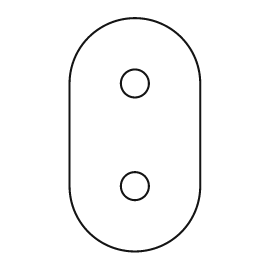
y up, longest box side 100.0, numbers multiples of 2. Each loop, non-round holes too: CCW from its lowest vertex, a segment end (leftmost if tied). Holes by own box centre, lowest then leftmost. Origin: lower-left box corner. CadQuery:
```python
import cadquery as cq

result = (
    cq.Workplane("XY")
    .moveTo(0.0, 28.0)
    .threePointArc((28.0, 0.0), (56.0, 28.0))
    .lineTo(56.0, 72.0)
    .threePointArc((28.0, 100.0), (0.0, 72.0))
    .close()
    .moveTo(28.0, 28.0)
    .circle(6.0)
    .moveTo(28.0, 72.0)
    .circle(6.0)
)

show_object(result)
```